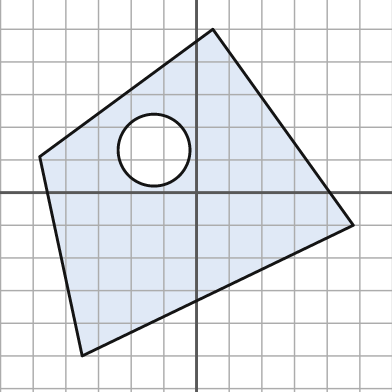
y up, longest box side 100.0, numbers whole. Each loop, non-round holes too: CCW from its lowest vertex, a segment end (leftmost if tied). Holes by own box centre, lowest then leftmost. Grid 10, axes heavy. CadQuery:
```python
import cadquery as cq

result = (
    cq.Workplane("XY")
    .moveTo(-35.0, -50.0)
    .lineTo(48.0, -10.0)
    .lineTo(5.0, 50.0)
    .lineTo(-48.0, 11.0)
    .close()
    .moveTo(-13.0, 13.0)
    .circle(11.0)
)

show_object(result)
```